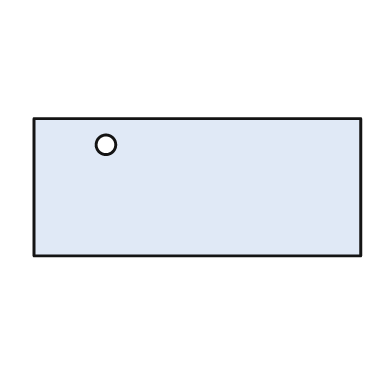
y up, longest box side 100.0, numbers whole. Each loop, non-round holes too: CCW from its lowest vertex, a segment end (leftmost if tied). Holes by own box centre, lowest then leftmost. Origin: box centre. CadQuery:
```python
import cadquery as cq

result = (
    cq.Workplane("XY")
    .moveTo(-50.0, -21.0)
    .lineTo(50.0, -21.0)
    .lineTo(50.0, 21.0)
    .lineTo(-50.0, 21.0)
    .close()
    .moveTo(-28.0, 13.0)
    .circle(3.0)
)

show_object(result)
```